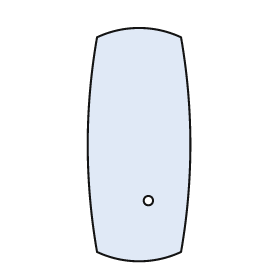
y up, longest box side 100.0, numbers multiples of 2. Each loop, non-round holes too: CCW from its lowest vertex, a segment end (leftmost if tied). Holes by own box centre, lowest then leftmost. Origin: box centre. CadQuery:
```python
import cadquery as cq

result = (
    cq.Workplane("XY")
    .moveTo(-18.0, -46.0)
    .threePointArc((0.0, -50.0), (18.0, -46.0))
    .threePointArc((22.0, 0.0), (18.0, 46.0))
    .threePointArc((0.0, 50.0), (-18.0, 46.0))
    .threePointArc((-22.0, 0.0), (-18.0, -46.0))
    .close()
    .moveTo(4.0, -24.0)
    .circle(2.0)
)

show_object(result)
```